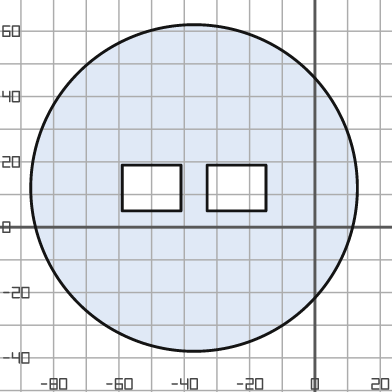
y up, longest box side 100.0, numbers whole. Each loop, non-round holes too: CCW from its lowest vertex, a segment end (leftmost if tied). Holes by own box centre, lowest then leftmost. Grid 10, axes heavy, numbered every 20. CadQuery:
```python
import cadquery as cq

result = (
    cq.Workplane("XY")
    .moveTo(-37.0, 12.0)
    .circle(50.0)
    .moveTo(-59.0, 5.0)
    .lineTo(-41.0, 5.0)
    .lineTo(-41.0, 19.0)
    .lineTo(-59.0, 19.0)
    .close()
    .moveTo(-33.0, 5.0)
    .lineTo(-15.0, 5.0)
    .lineTo(-15.0, 19.0)
    .lineTo(-33.0, 19.0)
    .close()
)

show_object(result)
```